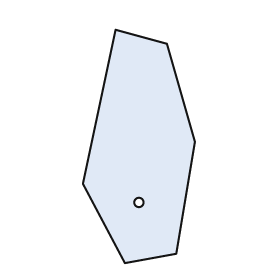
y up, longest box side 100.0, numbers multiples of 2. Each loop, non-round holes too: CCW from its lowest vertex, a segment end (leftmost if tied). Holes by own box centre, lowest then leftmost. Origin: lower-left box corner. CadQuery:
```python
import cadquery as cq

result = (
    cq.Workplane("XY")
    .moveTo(18.0, 0.0)
    .lineTo(40.0, 4.0)
    .lineTo(48.0, 52.0)
    .lineTo(36.0, 94.0)
    .lineTo(14.0, 100.0)
    .lineTo(0.0, 34.0)
    .close()
    .moveTo(24.0, 26.0)
    .circle(2.0)
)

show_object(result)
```